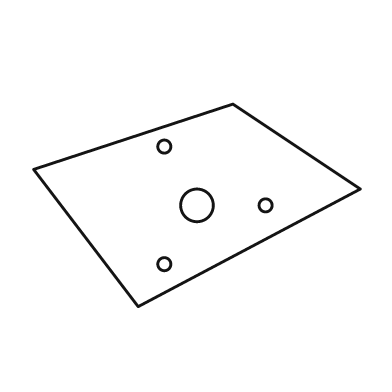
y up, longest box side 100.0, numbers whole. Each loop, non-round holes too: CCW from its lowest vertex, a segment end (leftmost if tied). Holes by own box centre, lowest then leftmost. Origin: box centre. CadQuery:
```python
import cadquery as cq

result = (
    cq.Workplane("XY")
    .moveTo(-18.0, -31.0)
    .lineTo(50.0, 5.0)
    .lineTo(11.0, 31.0)
    .lineTo(-50.0, 11.0)
    .close()
    .moveTo(-10.0, -18.0)
    .circle(2.0)
    .moveTo(0.0, 0.0)
    .circle(5.0)
    .moveTo(21.0, 0.0)
    .circle(2.0)
    .moveTo(-10.0, 18.0)
    .circle(2.0)
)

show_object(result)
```